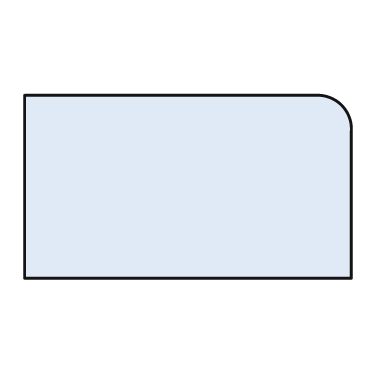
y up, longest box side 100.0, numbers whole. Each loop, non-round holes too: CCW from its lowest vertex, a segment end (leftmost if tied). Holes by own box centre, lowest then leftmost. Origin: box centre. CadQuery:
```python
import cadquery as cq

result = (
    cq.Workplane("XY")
    .moveTo(-50.0, -28.0)
    .lineTo(50.0, -28.0)
    .lineTo(50.0, 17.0)
    .threePointArc((47.0, 25.0), (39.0, 28.0))
    .lineTo(-50.0, 28.0)
    .close()
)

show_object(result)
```